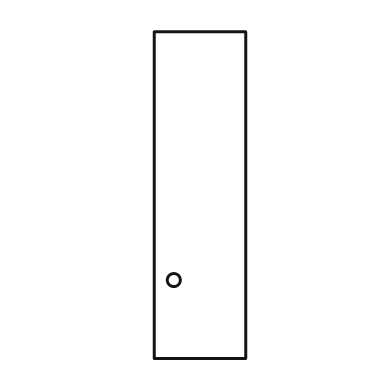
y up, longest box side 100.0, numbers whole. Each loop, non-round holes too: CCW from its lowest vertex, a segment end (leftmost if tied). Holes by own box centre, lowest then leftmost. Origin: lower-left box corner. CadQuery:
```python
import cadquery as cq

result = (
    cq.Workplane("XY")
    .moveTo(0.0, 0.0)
    .lineTo(28.0, 0.0)
    .lineTo(28.0, 100.0)
    .lineTo(0.0, 100.0)
    .close()
    .moveTo(6.0, 24.0)
    .circle(2.0)
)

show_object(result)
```